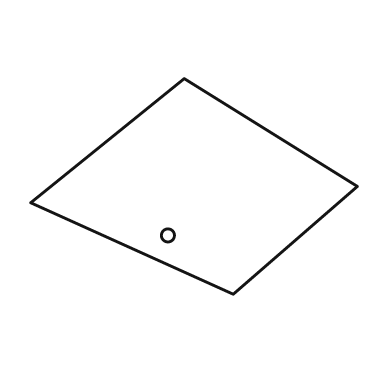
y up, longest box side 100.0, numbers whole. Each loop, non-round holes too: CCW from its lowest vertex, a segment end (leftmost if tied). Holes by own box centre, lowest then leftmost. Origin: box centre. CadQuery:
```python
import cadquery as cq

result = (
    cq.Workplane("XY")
    .moveTo(12.0, -33.0)
    .lineTo(50.0, 0.0)
    .lineTo(-3.0, 33.0)
    .lineTo(-50.0, -5.0)
    .close()
    .moveTo(-8.0, -15.0)
    .circle(2.0)
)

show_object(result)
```